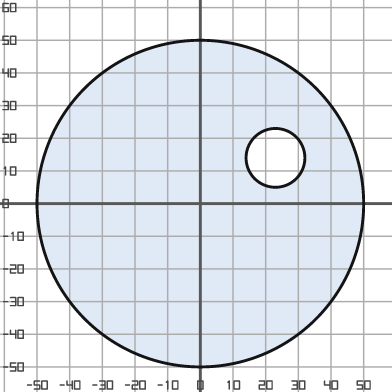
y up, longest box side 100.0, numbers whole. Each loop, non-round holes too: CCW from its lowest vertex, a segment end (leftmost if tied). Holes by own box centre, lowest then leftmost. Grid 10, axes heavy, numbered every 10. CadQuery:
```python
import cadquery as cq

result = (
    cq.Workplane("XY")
    .moveTo(0.0, 0.0)
    .circle(50.0)
    .moveTo(23.0, 14.0)
    .circle(9.0)
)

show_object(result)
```